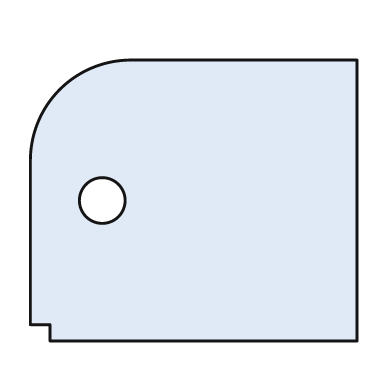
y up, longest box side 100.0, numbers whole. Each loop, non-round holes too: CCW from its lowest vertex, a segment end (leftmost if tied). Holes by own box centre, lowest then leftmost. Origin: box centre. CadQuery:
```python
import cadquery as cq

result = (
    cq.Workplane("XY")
    .moveTo(-44.0, -43.0)
    .lineTo(50.0, -43.0)
    .lineTo(50.0, 43.0)
    .lineTo(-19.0, 43.0)
    .threePointArc((-41.0, 34.0), (-50.0, 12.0))
    .lineTo(-50.0, -38.0)
    .lineTo(-44.0, -38.0)
    .close()
    .moveTo(-28.0, 0.0)
    .circle(7.0)
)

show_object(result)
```